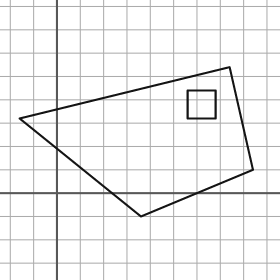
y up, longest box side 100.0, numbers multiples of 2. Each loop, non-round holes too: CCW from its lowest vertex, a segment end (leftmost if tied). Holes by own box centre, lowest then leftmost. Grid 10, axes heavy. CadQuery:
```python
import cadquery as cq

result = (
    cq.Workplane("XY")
    .moveTo(36.0, -10.0)
    .lineTo(84.0, 10.0)
    .lineTo(74.0, 54.0)
    .lineTo(-16.0, 32.0)
    .close()
    .moveTo(56.0, 32.0)
    .lineTo(68.0, 32.0)
    .lineTo(68.0, 44.0)
    .lineTo(56.0, 44.0)
    .close()
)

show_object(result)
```